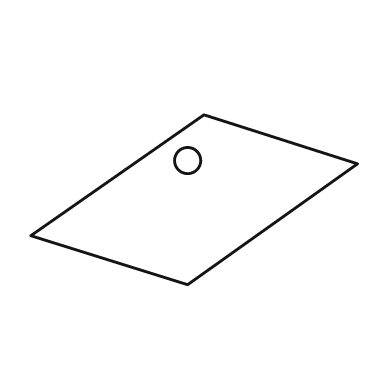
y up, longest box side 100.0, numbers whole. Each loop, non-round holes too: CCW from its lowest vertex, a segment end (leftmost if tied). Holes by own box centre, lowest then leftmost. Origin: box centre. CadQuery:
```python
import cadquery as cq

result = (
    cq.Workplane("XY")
    .moveTo(-2.0, -26.0)
    .lineTo(50.0, 11.0)
    .lineTo(3.0, 26.0)
    .lineTo(-50.0, -11.0)
    .close()
    .moveTo(-2.0, 12.0)
    .circle(4.0)
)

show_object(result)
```